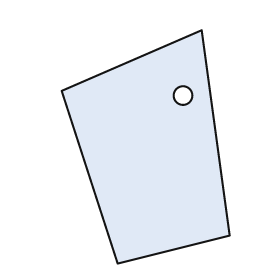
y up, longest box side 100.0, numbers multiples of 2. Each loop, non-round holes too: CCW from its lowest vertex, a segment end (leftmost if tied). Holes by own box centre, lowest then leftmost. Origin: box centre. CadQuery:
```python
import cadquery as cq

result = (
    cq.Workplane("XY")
    .moveTo(-12.0, -50.0)
    .lineTo(36.0, -38.0)
    .lineTo(24.0, 50.0)
    .lineTo(-36.0, 24.0)
    .close()
    .moveTo(16.0, 22.0)
    .circle(4.0)
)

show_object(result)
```